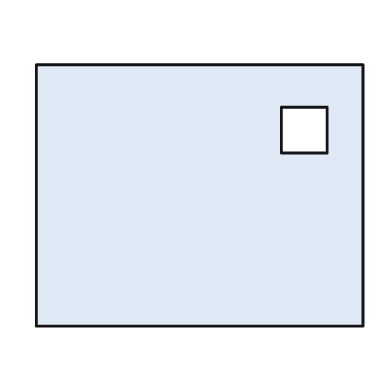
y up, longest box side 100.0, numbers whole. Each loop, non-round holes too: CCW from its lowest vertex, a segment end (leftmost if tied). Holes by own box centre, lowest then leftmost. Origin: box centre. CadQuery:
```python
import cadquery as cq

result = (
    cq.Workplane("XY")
    .moveTo(-50.0, -40.0)
    .lineTo(50.0, -40.0)
    .lineTo(50.0, 40.0)
    .lineTo(-50.0, 40.0)
    .close()
    .moveTo(25.0, 13.0)
    .lineTo(39.0, 13.0)
    .lineTo(39.0, 27.0)
    .lineTo(25.0, 27.0)
    .close()
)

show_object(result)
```